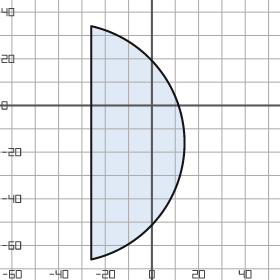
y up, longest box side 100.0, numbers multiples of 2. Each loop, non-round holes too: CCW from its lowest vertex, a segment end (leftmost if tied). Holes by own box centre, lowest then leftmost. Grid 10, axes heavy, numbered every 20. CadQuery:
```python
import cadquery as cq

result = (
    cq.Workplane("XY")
    .moveTo(-26.0, -66.0)
    .threePointArc((14.0, -16.0), (-26.0, 34.0))
    .close()
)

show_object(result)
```